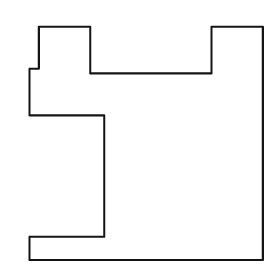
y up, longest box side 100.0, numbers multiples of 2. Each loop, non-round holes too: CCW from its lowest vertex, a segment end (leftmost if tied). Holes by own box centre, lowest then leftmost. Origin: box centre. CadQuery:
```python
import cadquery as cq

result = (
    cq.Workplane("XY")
    .moveTo(-50.0, -50.0)
    .lineTo(50.0, -50.0)
    .lineTo(50.0, 50.0)
    .lineTo(28.0, 50.0)
    .lineTo(28.0, 30.0)
    .lineTo(-24.0, 30.0)
    .lineTo(-24.0, 50.0)
    .lineTo(-46.0, 50.0)
    .lineTo(-46.0, 32.0)
    .lineTo(-50.0, 32.0)
    .lineTo(-50.0, 12.0)
    .lineTo(-18.0, 12.0)
    .lineTo(-18.0, -40.0)
    .lineTo(-50.0, -40.0)
    .close()
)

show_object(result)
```